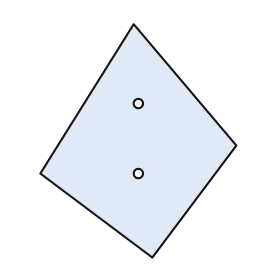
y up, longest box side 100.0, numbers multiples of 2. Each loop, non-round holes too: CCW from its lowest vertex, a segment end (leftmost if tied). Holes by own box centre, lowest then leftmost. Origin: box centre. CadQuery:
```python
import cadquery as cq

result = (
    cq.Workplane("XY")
    .moveTo(6.0, -50.0)
    .lineTo(42.0, -2.0)
    .lineTo(-2.0, 50.0)
    .lineTo(-42.0, -14.0)
    .close()
    .moveTo(0.0, -14.0)
    .circle(2.0)
    .moveTo(0.0, 16.0)
    .circle(2.0)
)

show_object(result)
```